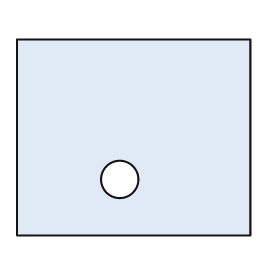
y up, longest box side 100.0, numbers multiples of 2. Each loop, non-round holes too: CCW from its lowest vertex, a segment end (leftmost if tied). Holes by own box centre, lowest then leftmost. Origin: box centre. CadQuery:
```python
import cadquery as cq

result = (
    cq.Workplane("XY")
    .moveTo(-50.0, -42.0)
    .lineTo(50.0, -42.0)
    .lineTo(50.0, 42.0)
    .lineTo(-50.0, 42.0)
    .close()
    .moveTo(-6.0, -18.0)
    .circle(8.0)
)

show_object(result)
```